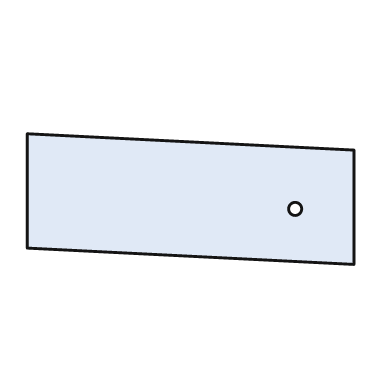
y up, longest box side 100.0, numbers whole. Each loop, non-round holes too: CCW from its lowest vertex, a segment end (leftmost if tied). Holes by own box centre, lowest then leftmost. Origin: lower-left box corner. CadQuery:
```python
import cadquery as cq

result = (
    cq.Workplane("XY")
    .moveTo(100.0, 0.0)
    .lineTo(100.0, 35.0)
    .lineTo(0.0, 40.0)
    .lineTo(0.0, 5.0)
    .close()
    .moveTo(82.0, 17.0)
    .circle(2.0)
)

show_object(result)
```